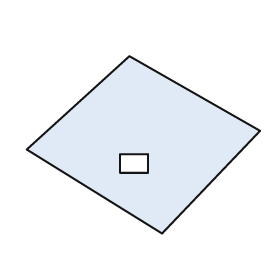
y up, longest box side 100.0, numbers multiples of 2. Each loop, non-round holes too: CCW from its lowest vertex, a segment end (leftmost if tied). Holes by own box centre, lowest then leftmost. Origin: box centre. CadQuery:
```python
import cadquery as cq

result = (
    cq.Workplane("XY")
    .moveTo(8.0, -38.0)
    .lineTo(50.0, 6.0)
    .lineTo(-6.0, 38.0)
    .lineTo(-50.0, -2.0)
    .close()
    .moveTo(-10.0, -12.0)
    .lineTo(2.0, -12.0)
    .lineTo(2.0, -4.0)
    .lineTo(-10.0, -4.0)
    .close()
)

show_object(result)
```